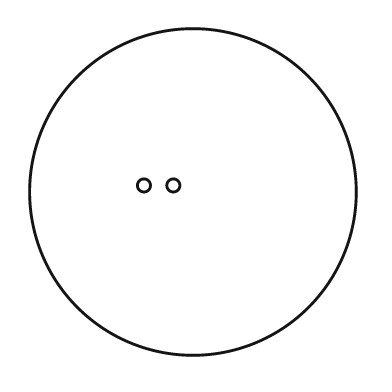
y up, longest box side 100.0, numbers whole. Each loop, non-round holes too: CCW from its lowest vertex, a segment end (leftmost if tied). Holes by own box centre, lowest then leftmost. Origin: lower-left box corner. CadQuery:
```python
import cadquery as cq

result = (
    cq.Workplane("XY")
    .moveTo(50.0, 50.0)
    .circle(50.0)
    .moveTo(35.0, 52.0)
    .circle(2.0)
    .moveTo(44.0, 52.0)
    .circle(2.0)
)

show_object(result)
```